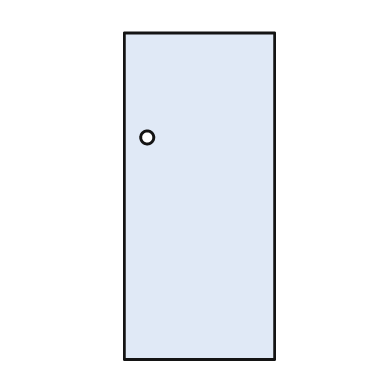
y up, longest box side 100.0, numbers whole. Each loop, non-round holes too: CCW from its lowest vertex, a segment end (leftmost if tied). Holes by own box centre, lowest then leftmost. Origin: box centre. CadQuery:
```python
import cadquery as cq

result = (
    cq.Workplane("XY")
    .moveTo(-23.0, -50.0)
    .lineTo(23.0, -50.0)
    .lineTo(23.0, 50.0)
    .lineTo(-23.0, 50.0)
    .close()
    .moveTo(-16.0, 18.0)
    .circle(2.0)
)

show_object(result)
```